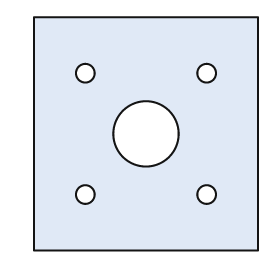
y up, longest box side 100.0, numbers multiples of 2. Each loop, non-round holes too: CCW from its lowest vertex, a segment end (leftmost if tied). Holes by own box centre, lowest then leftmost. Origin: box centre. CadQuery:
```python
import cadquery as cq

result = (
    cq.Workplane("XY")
    .moveTo(-48.0, -50.0)
    .lineTo(48.0, -50.0)
    .lineTo(48.0, 50.0)
    .lineTo(-48.0, 50.0)
    .close()
    .moveTo(-26.0, -26.0)
    .circle(4.0)
    .moveTo(26.0, -26.0)
    .circle(4.0)
    .moveTo(0.0, 0.0)
    .circle(14.0)
    .moveTo(-26.0, 26.0)
    .circle(4.0)
    .moveTo(26.0, 26.0)
    .circle(4.0)
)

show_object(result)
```